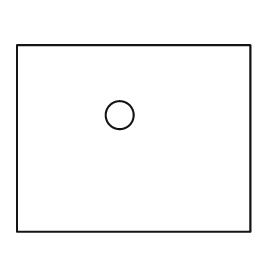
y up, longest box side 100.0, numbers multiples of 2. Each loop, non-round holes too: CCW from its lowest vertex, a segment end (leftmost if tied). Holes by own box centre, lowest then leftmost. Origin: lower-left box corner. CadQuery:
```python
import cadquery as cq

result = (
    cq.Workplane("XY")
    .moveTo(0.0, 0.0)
    .lineTo(100.0, 0.0)
    .lineTo(100.0, 80.0)
    .lineTo(0.0, 80.0)
    .close()
    .moveTo(44.0, 50.0)
    .circle(6.0)
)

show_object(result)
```